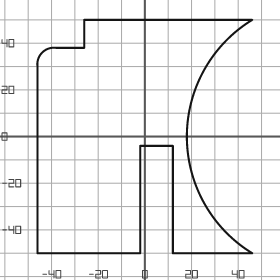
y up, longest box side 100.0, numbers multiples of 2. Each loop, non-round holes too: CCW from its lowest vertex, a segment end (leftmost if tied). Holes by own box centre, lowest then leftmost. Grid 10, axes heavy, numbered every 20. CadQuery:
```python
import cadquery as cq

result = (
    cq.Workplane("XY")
    .moveTo(-46.0, -50.0)
    .lineTo(-2.0, -50.0)
    .lineTo(-2.0, -4.0)
    .lineTo(12.0, -4.0)
    .lineTo(12.0, -50.0)
    .lineTo(46.0, -50.0)
    .threePointArc((18.0, 0.0), (46.0, 50.0))
    .lineTo(-26.0, 50.0)
    .lineTo(-26.0, 38.0)
    .lineTo(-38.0, 38.0)
    .threePointArc((-44.0, 36.0), (-46.0, 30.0))
    .close()
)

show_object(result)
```